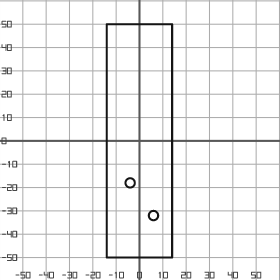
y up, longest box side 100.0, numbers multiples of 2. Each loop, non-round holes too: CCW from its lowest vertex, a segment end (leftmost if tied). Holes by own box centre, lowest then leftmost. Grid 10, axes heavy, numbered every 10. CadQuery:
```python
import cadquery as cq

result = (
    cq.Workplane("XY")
    .moveTo(-14.0, -50.0)
    .lineTo(14.0, -50.0)
    .lineTo(14.0, 50.0)
    .lineTo(-14.0, 50.0)
    .close()
    .moveTo(6.0, -32.0)
    .circle(2.0)
    .moveTo(-4.0, -18.0)
    .circle(2.0)
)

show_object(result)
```